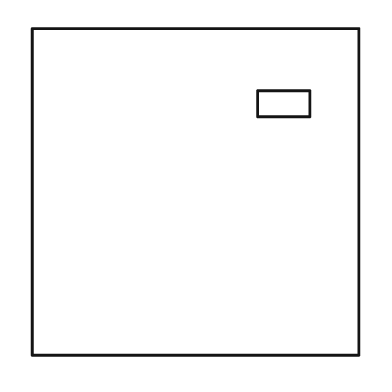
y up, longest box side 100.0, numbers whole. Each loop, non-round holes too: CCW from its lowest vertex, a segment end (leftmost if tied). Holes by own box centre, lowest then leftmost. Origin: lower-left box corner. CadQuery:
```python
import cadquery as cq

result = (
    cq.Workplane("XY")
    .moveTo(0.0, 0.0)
    .lineTo(100.0, 0.0)
    .lineTo(100.0, 100.0)
    .lineTo(0.0, 100.0)
    .close()
    .moveTo(69.0, 73.0)
    .lineTo(85.0, 73.0)
    .lineTo(85.0, 81.0)
    .lineTo(69.0, 81.0)
    .close()
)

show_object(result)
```